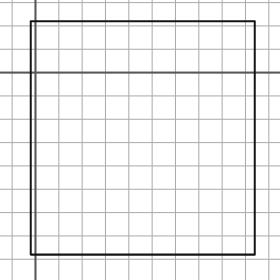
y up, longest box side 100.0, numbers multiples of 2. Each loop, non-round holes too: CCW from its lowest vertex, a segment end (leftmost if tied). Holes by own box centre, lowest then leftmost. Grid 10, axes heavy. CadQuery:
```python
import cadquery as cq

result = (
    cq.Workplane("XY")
    .moveTo(-2.0, -78.0)
    .lineTo(94.0, -78.0)
    .lineTo(94.0, 22.0)
    .lineTo(-2.0, 22.0)
    .close()
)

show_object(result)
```